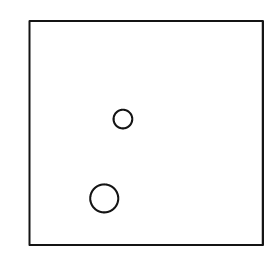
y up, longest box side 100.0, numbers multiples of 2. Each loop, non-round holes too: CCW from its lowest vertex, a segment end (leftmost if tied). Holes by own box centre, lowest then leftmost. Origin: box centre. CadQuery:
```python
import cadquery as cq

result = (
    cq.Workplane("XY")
    .moveTo(-50.0, -48.0)
    .lineTo(50.0, -48.0)
    .lineTo(50.0, 48.0)
    .lineTo(-50.0, 48.0)
    .close()
    .moveTo(-18.0, -28.0)
    .circle(6.0)
    .moveTo(-10.0, 6.0)
    .circle(4.0)
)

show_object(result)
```